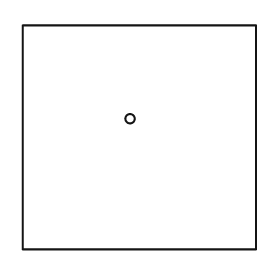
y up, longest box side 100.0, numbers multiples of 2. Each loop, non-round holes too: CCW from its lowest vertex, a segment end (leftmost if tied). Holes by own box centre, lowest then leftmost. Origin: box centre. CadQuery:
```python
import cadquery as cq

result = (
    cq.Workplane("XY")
    .moveTo(-50.0, -48.0)
    .lineTo(50.0, -48.0)
    .lineTo(50.0, 48.0)
    .lineTo(-50.0, 48.0)
    .close()
    .moveTo(-4.0, 8.0)
    .circle(2.0)
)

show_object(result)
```